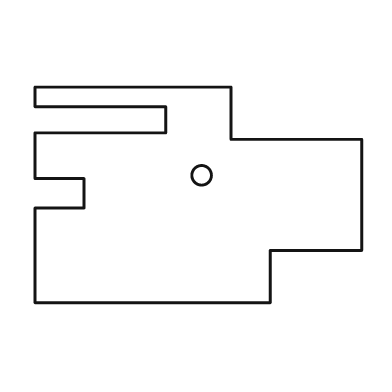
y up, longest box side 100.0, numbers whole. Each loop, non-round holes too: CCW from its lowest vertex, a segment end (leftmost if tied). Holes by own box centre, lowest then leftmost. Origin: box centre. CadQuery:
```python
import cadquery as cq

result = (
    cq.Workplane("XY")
    .moveTo(-50.0, -33.0)
    .lineTo(22.0, -33.0)
    .lineTo(22.0, -17.0)
    .lineTo(50.0, -17.0)
    .lineTo(50.0, 17.0)
    .lineTo(10.0, 17.0)
    .lineTo(10.0, 33.0)
    .lineTo(-50.0, 33.0)
    .lineTo(-50.0, 27.0)
    .lineTo(-10.0, 27.0)
    .lineTo(-10.0, 19.0)
    .lineTo(-50.0, 19.0)
    .lineTo(-50.0, 5.0)
    .lineTo(-35.0, 5.0)
    .lineTo(-35.0, -4.0)
    .lineTo(-50.0, -4.0)
    .close()
    .moveTo(1.0, 6.0)
    .circle(3.0)
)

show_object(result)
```